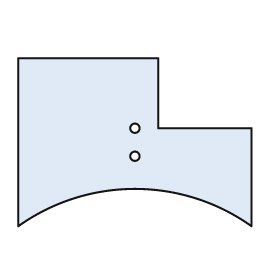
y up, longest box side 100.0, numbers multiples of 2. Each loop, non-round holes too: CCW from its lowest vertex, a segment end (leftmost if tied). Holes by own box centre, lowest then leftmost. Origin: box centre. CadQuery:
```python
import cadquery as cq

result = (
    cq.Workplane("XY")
    .moveTo(-50.0, -36.0)
    .threePointArc((0.0, -20.0), (50.0, -36.0))
    .lineTo(50.0, 6.0)
    .lineTo(10.0, 6.0)
    .lineTo(10.0, 36.0)
    .lineTo(-50.0, 36.0)
    .close()
    .moveTo(0.0, -6.0)
    .circle(2.0)
    .moveTo(0.0, 6.0)
    .circle(2.0)
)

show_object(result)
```